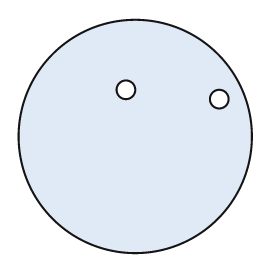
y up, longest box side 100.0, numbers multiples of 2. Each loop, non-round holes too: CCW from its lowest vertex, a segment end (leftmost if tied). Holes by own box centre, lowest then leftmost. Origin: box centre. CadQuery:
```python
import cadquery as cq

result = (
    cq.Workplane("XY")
    .moveTo(0.0, 0.0)
    .circle(50.0)
    .moveTo(36.0, 16.0)
    .circle(4.0)
    .moveTo(-4.0, 20.0)
    .circle(4.0)
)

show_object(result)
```